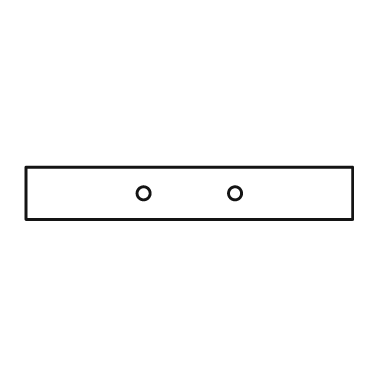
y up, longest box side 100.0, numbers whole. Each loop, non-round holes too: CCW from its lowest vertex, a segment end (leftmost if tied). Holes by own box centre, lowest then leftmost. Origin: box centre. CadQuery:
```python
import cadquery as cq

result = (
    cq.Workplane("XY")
    .moveTo(-50.0, -8.0)
    .lineTo(50.0, -8.0)
    .lineTo(50.0, 8.0)
    .lineTo(-50.0, 8.0)
    .close()
    .moveTo(-14.0, 0.0)
    .circle(2.0)
    .moveTo(14.0, 0.0)
    .circle(2.0)
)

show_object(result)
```